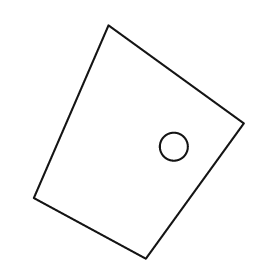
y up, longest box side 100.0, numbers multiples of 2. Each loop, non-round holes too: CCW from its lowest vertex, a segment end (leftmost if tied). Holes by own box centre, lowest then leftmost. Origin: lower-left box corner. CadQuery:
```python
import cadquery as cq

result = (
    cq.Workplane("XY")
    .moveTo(48.0, 0.0)
    .lineTo(90.0, 58.0)
    .lineTo(32.0, 100.0)
    .lineTo(0.0, 26.0)
    .close()
    .moveTo(60.0, 48.0)
    .circle(6.0)
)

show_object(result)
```